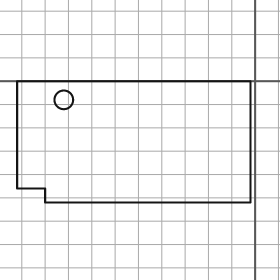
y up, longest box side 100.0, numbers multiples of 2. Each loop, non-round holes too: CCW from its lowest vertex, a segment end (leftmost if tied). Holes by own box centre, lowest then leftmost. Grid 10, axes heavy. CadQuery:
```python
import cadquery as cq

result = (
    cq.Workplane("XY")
    .moveTo(-90.0, -52.0)
    .lineTo(-2.0, -52.0)
    .lineTo(-2.0, 0.0)
    .lineTo(-102.0, 0.0)
    .lineTo(-102.0, -46.0)
    .lineTo(-90.0, -46.0)
    .close()
    .moveTo(-82.0, -8.0)
    .circle(4.0)
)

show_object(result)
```